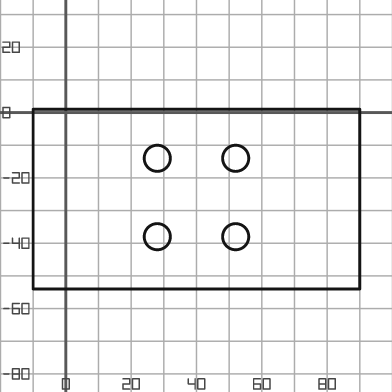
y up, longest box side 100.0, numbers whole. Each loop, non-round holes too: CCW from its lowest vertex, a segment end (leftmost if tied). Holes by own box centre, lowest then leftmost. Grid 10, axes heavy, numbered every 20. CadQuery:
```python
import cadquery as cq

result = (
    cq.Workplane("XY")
    .moveTo(-10.0, -54.0)
    .lineTo(90.0, -54.0)
    .lineTo(90.0, 1.0)
    .lineTo(-10.0, 1.0)
    .close()
    .moveTo(28.0, -38.0)
    .circle(4.0)
    .moveTo(52.0, -38.0)
    .circle(4.0)
    .moveTo(28.0, -14.0)
    .circle(4.0)
    .moveTo(52.0, -14.0)
    .circle(4.0)
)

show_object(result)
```